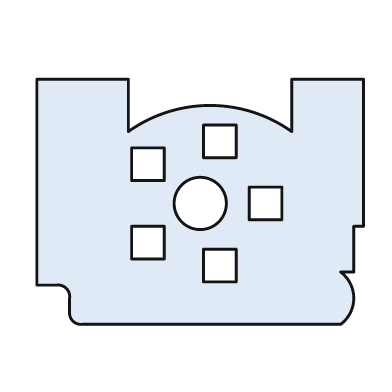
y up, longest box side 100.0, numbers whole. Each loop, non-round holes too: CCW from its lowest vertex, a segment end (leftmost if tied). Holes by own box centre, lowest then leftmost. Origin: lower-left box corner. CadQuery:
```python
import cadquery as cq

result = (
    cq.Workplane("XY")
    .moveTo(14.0, 0.0)
    .lineTo(93.0, 0.0)
    .threePointArc((97.0, 8.0), (93.0, 16.0))
    .lineTo(97.0, 16.0)
    .lineTo(97.0, 30.0)
    .lineTo(100.0, 30.0)
    .lineTo(100.0, 75.0)
    .lineTo(78.0, 75.0)
    .lineTo(78.0, 59.0)
    .threePointArc((53.0, 67.0), (28.0, 59.0))
    .lineTo(28.0, 75.0)
    .lineTo(0.0, 75.0)
    .lineTo(0.0, 12.0)
    .lineTo(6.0, 12.0)
    .threePointArc((9.0, 11.0), (10.0, 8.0))
    .lineTo(10.0, 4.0)
    .threePointArc((11.0, 1.0), (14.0, 0.0))
    .close()
    .moveTo(51.0, 13.0)
    .lineTo(61.0, 13.0)
    .lineTo(61.0, 23.0)
    .lineTo(51.0, 23.0)
    .close()
    .moveTo(29.0, 20.0)
    .lineTo(39.0, 20.0)
    .lineTo(39.0, 30.0)
    .lineTo(29.0, 30.0)
    .close()
    .moveTo(50.0, 37.0)
    .circle(8.0)
    .moveTo(65.0, 32.0)
    .lineTo(75.0, 32.0)
    .lineTo(75.0, 42.0)
    .lineTo(65.0, 42.0)
    .close()
    .moveTo(29.0, 44.0)
    .lineTo(39.0, 44.0)
    .lineTo(39.0, 54.0)
    .lineTo(29.0, 54.0)
    .close()
    .moveTo(51.0, 51.0)
    .lineTo(61.0, 51.0)
    .lineTo(61.0, 61.0)
    .lineTo(51.0, 61.0)
    .close()
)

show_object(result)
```